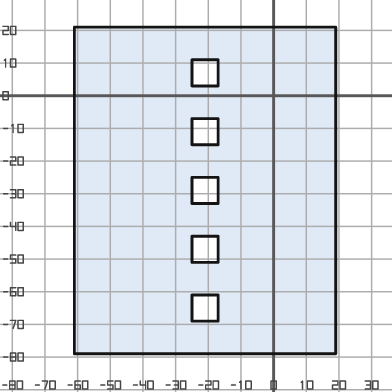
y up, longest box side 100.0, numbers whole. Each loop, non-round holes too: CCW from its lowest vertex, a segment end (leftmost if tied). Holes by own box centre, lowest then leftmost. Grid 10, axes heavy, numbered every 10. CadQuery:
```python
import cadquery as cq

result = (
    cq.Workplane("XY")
    .moveTo(-61.0, -79.0)
    .lineTo(19.0, -79.0)
    .lineTo(19.0, 21.0)
    .lineTo(-61.0, 21.0)
    .close()
    .moveTo(-25.0, -69.0)
    .lineTo(-17.0, -69.0)
    .lineTo(-17.0, -61.0)
    .lineTo(-25.0, -61.0)
    .close()
    .moveTo(-25.0, -51.0)
    .lineTo(-17.0, -51.0)
    .lineTo(-17.0, -43.0)
    .lineTo(-25.0, -43.0)
    .close()
    .moveTo(-25.0, -33.0)
    .lineTo(-17.0, -33.0)
    .lineTo(-17.0, -25.0)
    .lineTo(-25.0, -25.0)
    .close()
    .moveTo(-25.0, -15.0)
    .lineTo(-17.0, -15.0)
    .lineTo(-17.0, -7.0)
    .lineTo(-25.0, -7.0)
    .close()
    .moveTo(-25.0, 3.0)
    .lineTo(-17.0, 3.0)
    .lineTo(-17.0, 11.0)
    .lineTo(-25.0, 11.0)
    .close()
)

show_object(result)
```